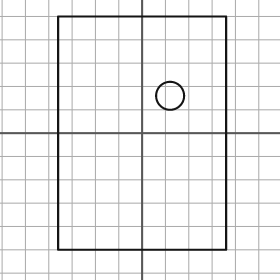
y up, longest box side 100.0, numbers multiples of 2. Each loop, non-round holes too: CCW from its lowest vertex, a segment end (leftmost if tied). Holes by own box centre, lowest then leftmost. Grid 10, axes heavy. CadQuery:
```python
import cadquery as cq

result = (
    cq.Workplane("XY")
    .moveTo(-36.0, -50.0)
    .lineTo(36.0, -50.0)
    .lineTo(36.0, 50.0)
    .lineTo(-36.0, 50.0)
    .close()
    .moveTo(12.0, 16.0)
    .circle(6.0)
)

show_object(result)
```